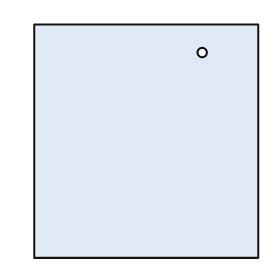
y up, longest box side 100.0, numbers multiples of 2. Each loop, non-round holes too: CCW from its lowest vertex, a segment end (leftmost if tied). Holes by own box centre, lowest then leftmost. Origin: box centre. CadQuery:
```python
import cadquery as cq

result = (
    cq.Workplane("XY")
    .moveTo(-48.0, -50.0)
    .lineTo(48.0, -50.0)
    .lineTo(48.0, 50.0)
    .lineTo(-48.0, 50.0)
    .close()
    .moveTo(24.0, 38.0)
    .circle(2.0)
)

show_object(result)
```